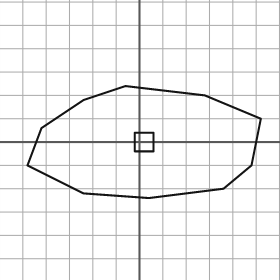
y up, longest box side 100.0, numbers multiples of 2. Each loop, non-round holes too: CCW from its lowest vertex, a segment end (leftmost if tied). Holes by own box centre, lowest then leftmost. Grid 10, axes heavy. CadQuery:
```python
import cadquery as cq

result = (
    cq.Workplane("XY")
    .moveTo(4.0, -24.0)
    .lineTo(36.0, -20.0)
    .lineTo(48.0, -10.0)
    .lineTo(52.0, 10.0)
    .lineTo(28.0, 20.0)
    .lineTo(-6.0, 24.0)
    .lineTo(-24.0, 18.0)
    .lineTo(-42.0, 6.0)
    .lineTo(-48.0, -10.0)
    .lineTo(-24.0, -22.0)
    .close()
    .moveTo(-2.0, -4.0)
    .lineTo(6.0, -4.0)
    .lineTo(6.0, 4.0)
    .lineTo(-2.0, 4.0)
    .close()
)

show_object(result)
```